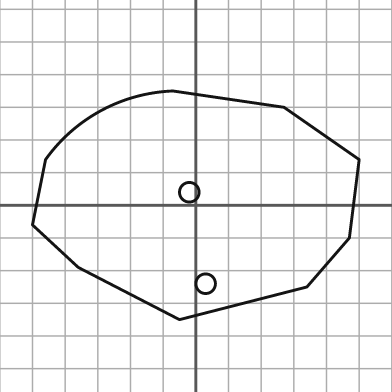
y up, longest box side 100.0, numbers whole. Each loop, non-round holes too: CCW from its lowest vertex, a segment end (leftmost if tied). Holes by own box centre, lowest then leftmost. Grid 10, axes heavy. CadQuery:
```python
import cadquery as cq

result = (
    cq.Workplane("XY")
    .moveTo(-5.0, -35.0)
    .lineTo(34.0, -25.0)
    .lineTo(47.0, -10.0)
    .lineTo(50.0, 14.0)
    .lineTo(27.0, 30.0)
    .lineTo(-7.0, 35.0)
    .threePointArc((-29.0, 29.0), (-46.0, 14.0))
    .lineTo(-50.0, -6.0)
    .lineTo(-36.0, -19.0)
    .close()
    .moveTo(3.0, -24.0)
    .circle(3.0)
    .moveTo(-2.0, 4.0)
    .circle(3.0)
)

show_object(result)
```